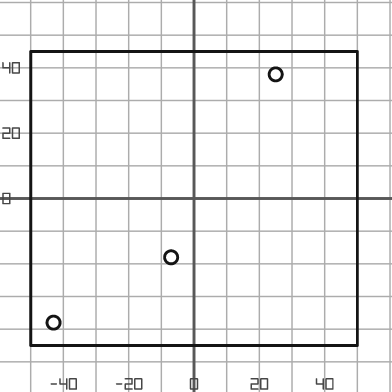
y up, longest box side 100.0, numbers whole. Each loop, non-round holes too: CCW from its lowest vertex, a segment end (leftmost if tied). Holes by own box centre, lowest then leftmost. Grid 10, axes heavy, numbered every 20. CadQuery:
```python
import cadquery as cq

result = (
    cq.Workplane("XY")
    .moveTo(-50.0, -45.0)
    .lineTo(50.0, -45.0)
    .lineTo(50.0, 45.0)
    .lineTo(-50.0, 45.0)
    .close()
    .moveTo(-43.0, -38.0)
    .circle(2.0)
    .moveTo(-7.0, -18.0)
    .circle(2.0)
    .moveTo(25.0, 38.0)
    .circle(2.0)
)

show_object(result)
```